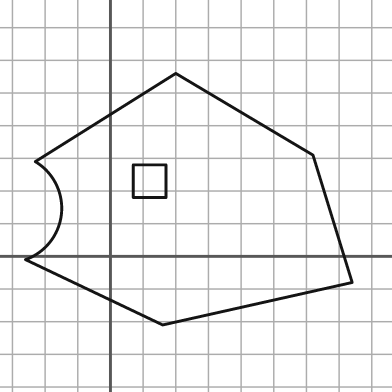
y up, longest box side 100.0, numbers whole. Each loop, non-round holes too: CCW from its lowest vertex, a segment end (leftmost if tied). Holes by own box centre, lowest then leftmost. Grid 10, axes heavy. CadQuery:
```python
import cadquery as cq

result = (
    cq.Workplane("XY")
    .moveTo(16.0, -21.0)
    .lineTo(74.0, -8.0)
    .lineTo(62.0, 31.0)
    .lineTo(20.0, 56.0)
    .lineTo(-23.0, 29.0)
    .threePointArc((-15.0, 13.0), (-26.0, -1.0))
    .close()
    .moveTo(7.0, 18.0)
    .lineTo(17.0, 18.0)
    .lineTo(17.0, 28.0)
    .lineTo(7.0, 28.0)
    .close()
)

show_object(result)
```